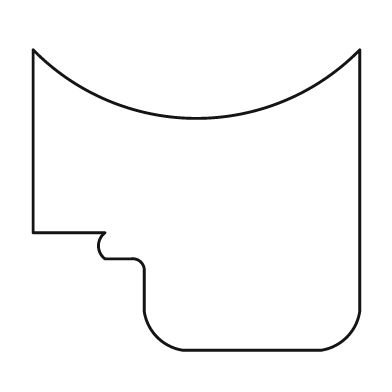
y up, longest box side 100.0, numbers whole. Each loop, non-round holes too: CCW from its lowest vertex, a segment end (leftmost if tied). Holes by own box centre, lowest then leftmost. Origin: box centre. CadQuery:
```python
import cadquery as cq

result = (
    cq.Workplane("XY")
    .moveTo(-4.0, -46.0)
    .lineTo(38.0, -46.0)
    .threePointArc((46.0, -42.0), (50.0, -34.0))
    .lineTo(50.0, 46.0)
    .threePointArc((0.0, 25.0), (-50.0, 46.0))
    .lineTo(-50.0, -10.0)
    .lineTo(-28.0, -10.0)
    .threePointArc((-30.0, -14.0), (-28.0, -18.0))
    .lineTo(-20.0, -18.0)
    .threePointArc((-17.0, -19.0), (-16.0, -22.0))
    .lineTo(-16.0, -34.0)
    .threePointArc((-12.0, -42.0), (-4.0, -46.0))
    .close()
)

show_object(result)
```